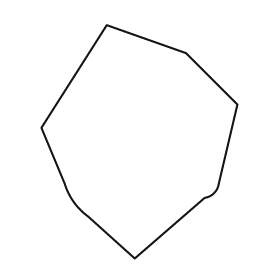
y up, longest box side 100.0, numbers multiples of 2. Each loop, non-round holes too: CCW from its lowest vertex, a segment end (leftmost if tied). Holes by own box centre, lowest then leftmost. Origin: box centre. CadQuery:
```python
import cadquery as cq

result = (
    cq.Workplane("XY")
    .moveTo(-2.0, -50.0)
    .lineTo(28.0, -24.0)
    .threePointArc((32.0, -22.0), (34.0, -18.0))
    .lineTo(42.0, 16.0)
    .lineTo(20.0, 38.0)
    .lineTo(-14.0, 50.0)
    .lineTo(-42.0, 6.0)
    .lineTo(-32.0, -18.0)
    .threePointArc((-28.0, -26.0), (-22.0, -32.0))
    .close()
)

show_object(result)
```